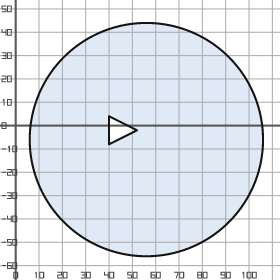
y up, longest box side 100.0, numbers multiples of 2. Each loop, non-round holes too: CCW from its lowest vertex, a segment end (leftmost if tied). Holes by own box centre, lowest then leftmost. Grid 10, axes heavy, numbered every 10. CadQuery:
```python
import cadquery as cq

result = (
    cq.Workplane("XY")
    .moveTo(56.0, -6.0)
    .circle(50.0)
    .moveTo(40.0, -8.0)
    .lineTo(52.0, -2.0)
    .lineTo(40.0, 4.0)
    .close()
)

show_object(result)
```